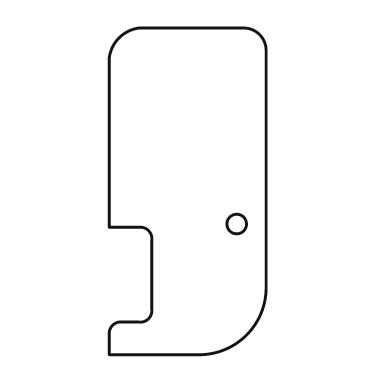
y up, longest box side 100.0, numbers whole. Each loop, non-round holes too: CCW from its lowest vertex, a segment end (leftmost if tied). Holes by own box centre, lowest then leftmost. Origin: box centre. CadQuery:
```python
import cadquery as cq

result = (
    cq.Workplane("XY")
    .moveTo(-24.0, -50.0)
    .lineTo(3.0, -50.0)
    .threePointArc((18.0, -44.0), (24.0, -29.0))
    .lineTo(24.0, 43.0)
    .threePointArc((22.0, 48.0), (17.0, 50.0))
    .lineTo(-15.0, 50.0)
    .threePointArc((-21.0, 47.0), (-24.0, 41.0))
    .lineTo(-24.0, -11.0)
    .lineTo(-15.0, -11.0)
    .threePointArc((-12.0, -12.0), (-11.0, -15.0))
    .lineTo(-11.0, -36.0)
    .threePointArc((-12.0, -39.0), (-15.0, -40.0))
    .lineTo(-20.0, -40.0)
    .threePointArc((-23.0, -41.0), (-24.0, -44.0))
    .close()
    .moveTo(15.0, -10.0)
    .circle(3.0)
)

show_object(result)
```